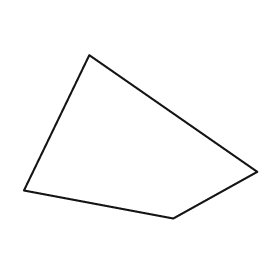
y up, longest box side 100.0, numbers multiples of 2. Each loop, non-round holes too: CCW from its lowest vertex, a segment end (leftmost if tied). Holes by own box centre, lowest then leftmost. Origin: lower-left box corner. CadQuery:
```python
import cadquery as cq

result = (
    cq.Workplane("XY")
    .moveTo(64.0, 0.0)
    .lineTo(100.0, 20.0)
    .lineTo(28.0, 70.0)
    .lineTo(0.0, 12.0)
    .close()
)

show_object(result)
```